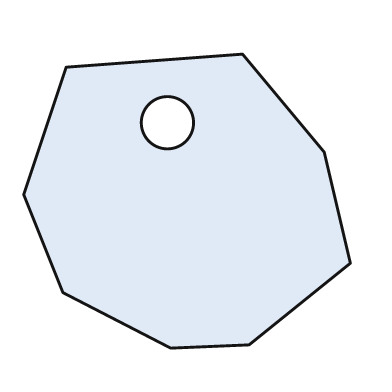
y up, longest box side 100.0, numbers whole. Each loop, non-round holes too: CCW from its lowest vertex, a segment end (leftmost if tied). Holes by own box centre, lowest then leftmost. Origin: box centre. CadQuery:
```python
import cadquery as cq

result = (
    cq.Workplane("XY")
    .moveTo(-5.0, -45.0)
    .lineTo(19.0, -44.0)
    .lineTo(50.0, -19.0)
    .lineTo(42.0, 15.0)
    .lineTo(17.0, 45.0)
    .lineTo(-37.0, 41.0)
    .lineTo(-50.0, 2.0)
    .lineTo(-38.0, -28.0)
    .close()
    .moveTo(-6.0, 24.0)
    .circle(8.0)
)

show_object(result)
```